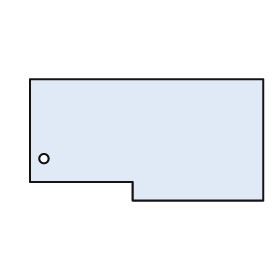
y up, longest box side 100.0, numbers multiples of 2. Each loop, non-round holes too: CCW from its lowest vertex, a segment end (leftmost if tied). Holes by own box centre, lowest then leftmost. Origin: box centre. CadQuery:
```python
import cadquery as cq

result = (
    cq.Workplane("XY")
    .moveTo(-6.0, -26.0)
    .lineTo(50.0, -26.0)
    .lineTo(50.0, 26.0)
    .lineTo(-50.0, 26.0)
    .lineTo(-50.0, -18.0)
    .lineTo(-6.0, -18.0)
    .close()
    .moveTo(-44.0, -8.0)
    .circle(2.0)
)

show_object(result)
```